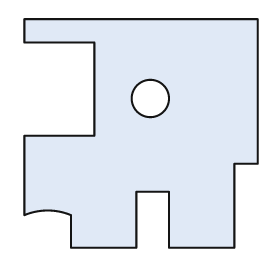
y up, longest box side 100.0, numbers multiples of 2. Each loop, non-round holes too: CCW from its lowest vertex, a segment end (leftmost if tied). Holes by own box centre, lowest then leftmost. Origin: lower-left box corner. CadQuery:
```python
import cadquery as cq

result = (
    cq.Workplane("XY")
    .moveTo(20.0, 0.0)
    .lineTo(48.0, 0.0)
    .lineTo(48.0, 24.0)
    .lineTo(62.0, 24.0)
    .lineTo(62.0, 0.0)
    .lineTo(90.0, 0.0)
    .lineTo(90.0, 36.0)
    .lineTo(100.0, 36.0)
    .lineTo(100.0, 98.0)
    .lineTo(0.0, 98.0)
    .lineTo(0.0, 88.0)
    .lineTo(30.0, 88.0)
    .lineTo(30.0, 48.0)
    .lineTo(0.0, 48.0)
    .lineTo(0.0, 14.0)
    .threePointArc((10.0, 16.0), (20.0, 14.0))
    .close()
    .moveTo(54.0, 64.0)
    .circle(8.0)
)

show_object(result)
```